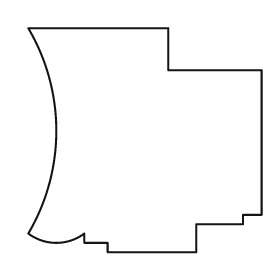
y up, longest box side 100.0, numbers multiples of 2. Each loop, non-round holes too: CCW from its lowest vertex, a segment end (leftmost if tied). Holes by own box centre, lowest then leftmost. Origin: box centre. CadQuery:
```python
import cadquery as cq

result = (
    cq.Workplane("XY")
    .moveTo(-16.0, -48.0)
    .lineTo(22.0, -48.0)
    .lineTo(22.0, -36.0)
    .lineTo(42.0, -36.0)
    .lineTo(42.0, -32.0)
    .lineTo(50.0, -32.0)
    .lineTo(50.0, 30.0)
    .lineTo(10.0, 30.0)
    .lineTo(10.0, 48.0)
    .lineTo(-50.0, 48.0)
    .threePointArc((-38.0, 4.0), (-50.0, -40.0))
    .threePointArc((-38.0, -44.0), (-26.0, -40.0))
    .lineTo(-26.0, -44.0)
    .lineTo(-16.0, -44.0)
    .close()
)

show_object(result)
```